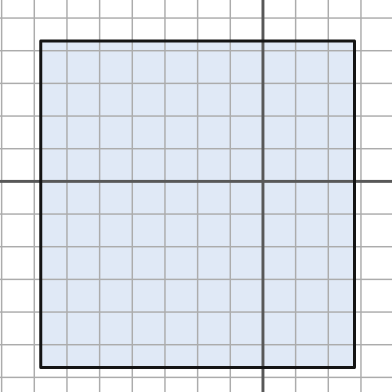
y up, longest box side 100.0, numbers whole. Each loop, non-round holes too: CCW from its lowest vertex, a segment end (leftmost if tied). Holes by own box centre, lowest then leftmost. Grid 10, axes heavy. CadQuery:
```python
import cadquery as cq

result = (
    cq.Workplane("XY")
    .moveTo(-68.0, -57.0)
    .lineTo(28.0, -57.0)
    .lineTo(28.0, 43.0)
    .lineTo(-68.0, 43.0)
    .close()
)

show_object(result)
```